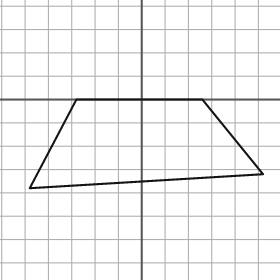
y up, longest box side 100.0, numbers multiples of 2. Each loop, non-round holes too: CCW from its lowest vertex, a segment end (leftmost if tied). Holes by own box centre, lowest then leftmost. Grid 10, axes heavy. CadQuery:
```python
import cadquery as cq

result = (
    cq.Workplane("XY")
    .moveTo(-48.0, -38.0)
    .lineTo(52.0, -32.0)
    .lineTo(26.0, 0.0)
    .lineTo(-28.0, 0.0)
    .close()
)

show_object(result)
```